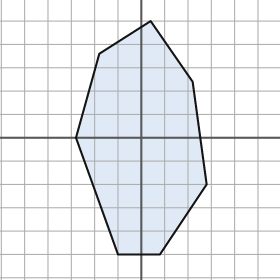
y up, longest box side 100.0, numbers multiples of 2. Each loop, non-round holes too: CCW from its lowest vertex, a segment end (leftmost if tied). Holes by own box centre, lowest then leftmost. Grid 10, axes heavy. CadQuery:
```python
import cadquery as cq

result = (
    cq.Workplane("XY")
    .moveTo(-10.0, -50.0)
    .lineTo(8.0, -50.0)
    .lineTo(28.0, -20.0)
    .lineTo(22.0, 24.0)
    .lineTo(4.0, 50.0)
    .lineTo(-18.0, 36.0)
    .lineTo(-28.0, 0.0)
    .close()
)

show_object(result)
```